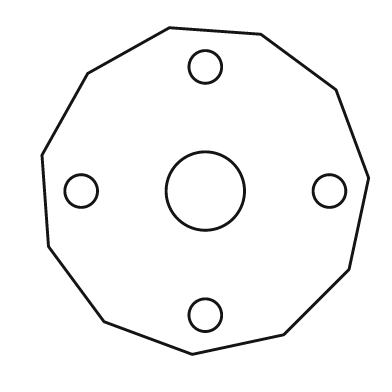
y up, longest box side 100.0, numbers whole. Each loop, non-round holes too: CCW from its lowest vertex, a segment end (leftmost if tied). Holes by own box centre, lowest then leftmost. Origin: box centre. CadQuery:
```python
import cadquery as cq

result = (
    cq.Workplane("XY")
    .moveTo(-4.0, -50.0)
    .lineTo(24.0, -44.0)
    .lineTo(44.0, -24.0)
    .lineTo(50.0, 4.0)
    .lineTo(40.0, 31.0)
    .lineTo(17.0, 48.0)
    .lineTo(-11.0, 50.0)
    .lineTo(-36.0, 36.0)
    .lineTo(-50.0, 11.0)
    .lineTo(-48.0, -17.0)
    .lineTo(-31.0, -40.0)
    .close()
    .moveTo(0.0, -38.0)
    .circle(5.0)
    .moveTo(-38.0, 0.0)
    .circle(5.0)
    .moveTo(0.0, 0.0)
    .circle(12.0)
    .moveTo(38.0, 0.0)
    .circle(5.0)
    .moveTo(0.0, 38.0)
    .circle(5.0)
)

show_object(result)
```